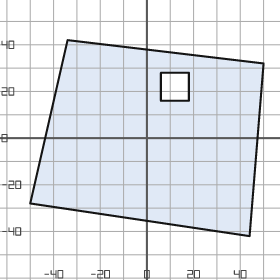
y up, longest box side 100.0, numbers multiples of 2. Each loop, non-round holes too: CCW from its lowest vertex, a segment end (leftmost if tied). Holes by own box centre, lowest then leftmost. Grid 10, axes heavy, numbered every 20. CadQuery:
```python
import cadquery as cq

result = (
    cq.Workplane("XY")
    .moveTo(44.0, -42.0)
    .lineTo(50.0, 32.0)
    .lineTo(-34.0, 42.0)
    .lineTo(-50.0, -28.0)
    .close()
    .moveTo(6.0, 16.0)
    .lineTo(18.0, 16.0)
    .lineTo(18.0, 28.0)
    .lineTo(6.0, 28.0)
    .close()
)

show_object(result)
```